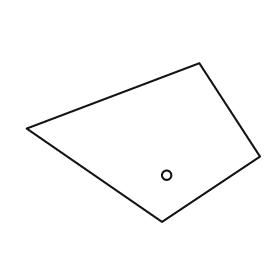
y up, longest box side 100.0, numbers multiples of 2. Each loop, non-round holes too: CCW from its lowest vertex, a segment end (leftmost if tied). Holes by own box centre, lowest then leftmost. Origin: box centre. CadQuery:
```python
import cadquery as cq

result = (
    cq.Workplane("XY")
    .moveTo(8.0, -34.0)
    .lineTo(50.0, -6.0)
    .lineTo(24.0, 34.0)
    .lineTo(-50.0, 6.0)
    .close()
    .moveTo(10.0, -14.0)
    .circle(2.0)
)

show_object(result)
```